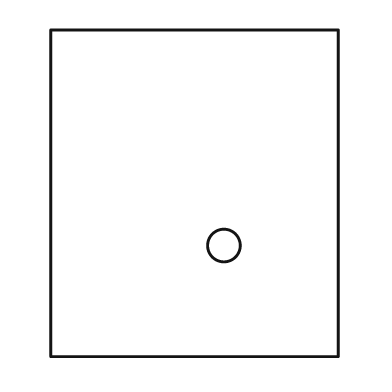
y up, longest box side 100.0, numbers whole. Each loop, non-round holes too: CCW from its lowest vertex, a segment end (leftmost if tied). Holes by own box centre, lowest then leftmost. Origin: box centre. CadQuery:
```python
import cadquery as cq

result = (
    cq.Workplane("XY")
    .moveTo(-44.0, -50.0)
    .lineTo(44.0, -50.0)
    .lineTo(44.0, 50.0)
    .lineTo(-44.0, 50.0)
    .close()
    .moveTo(9.0, -16.0)
    .circle(5.0)
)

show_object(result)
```